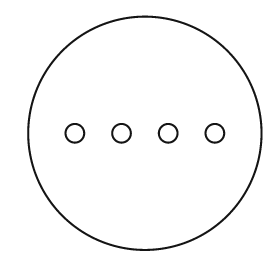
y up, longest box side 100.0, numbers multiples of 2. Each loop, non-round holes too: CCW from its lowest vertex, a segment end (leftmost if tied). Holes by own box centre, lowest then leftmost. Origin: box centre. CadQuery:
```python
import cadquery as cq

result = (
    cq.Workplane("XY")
    .moveTo(0.0, 0.0)
    .circle(50.0)
    .moveTo(-30.0, 0.0)
    .circle(4.0)
    .moveTo(-10.0, 0.0)
    .circle(4.0)
    .moveTo(10.0, 0.0)
    .circle(4.0)
    .moveTo(30.0, 0.0)
    .circle(4.0)
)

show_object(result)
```